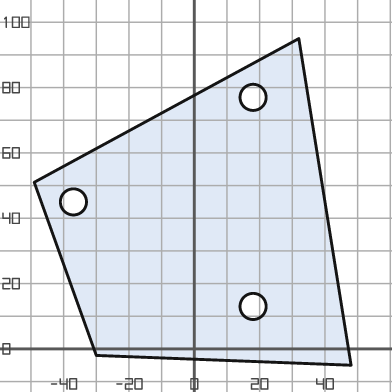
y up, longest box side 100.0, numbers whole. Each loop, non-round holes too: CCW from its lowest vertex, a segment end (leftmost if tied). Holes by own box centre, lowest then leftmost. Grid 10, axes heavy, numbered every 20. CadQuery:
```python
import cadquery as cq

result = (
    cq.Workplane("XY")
    .moveTo(48.0, -5.0)
    .lineTo(32.0, 95.0)
    .lineTo(-49.0, 51.0)
    .lineTo(-30.0, -2.0)
    .close()
    .moveTo(18.0, 13.0)
    .circle(4.0)
    .moveTo(-37.0, 45.0)
    .circle(4.0)
    .moveTo(18.0, 77.0)
    .circle(4.0)
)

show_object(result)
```